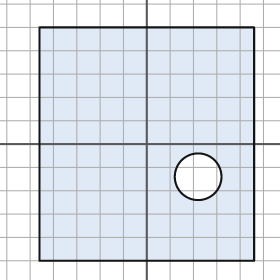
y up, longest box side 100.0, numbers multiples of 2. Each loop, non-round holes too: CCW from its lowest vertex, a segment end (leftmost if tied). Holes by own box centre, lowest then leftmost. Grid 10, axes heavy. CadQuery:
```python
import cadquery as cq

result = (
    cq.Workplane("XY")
    .moveTo(-46.0, -50.0)
    .lineTo(46.0, -50.0)
    .lineTo(46.0, 50.0)
    .lineTo(-46.0, 50.0)
    .close()
    .moveTo(22.0, -14.0)
    .circle(10.0)
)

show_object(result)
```